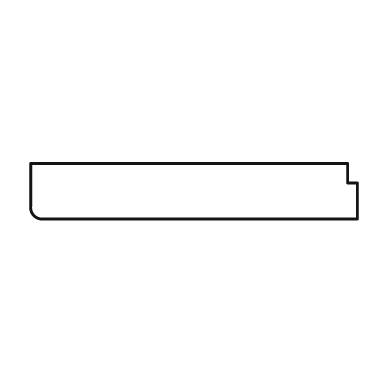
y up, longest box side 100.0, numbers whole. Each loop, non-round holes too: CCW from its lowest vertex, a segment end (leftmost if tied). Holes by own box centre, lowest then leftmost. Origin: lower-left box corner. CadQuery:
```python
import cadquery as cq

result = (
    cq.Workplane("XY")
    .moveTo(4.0, 0.0)
    .lineTo(100.0, 0.0)
    .lineTo(100.0, 11.0)
    .lineTo(97.0, 11.0)
    .lineTo(97.0, 17.0)
    .lineTo(0.0, 17.0)
    .lineTo(0.0, 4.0)
    .threePointArc((1.0, 1.0), (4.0, 0.0))
    .close()
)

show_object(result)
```